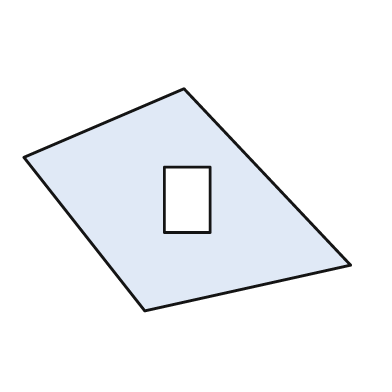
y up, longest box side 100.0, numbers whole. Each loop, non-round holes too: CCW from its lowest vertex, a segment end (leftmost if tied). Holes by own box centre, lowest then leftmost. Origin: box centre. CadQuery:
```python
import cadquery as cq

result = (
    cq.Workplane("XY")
    .moveTo(-13.0, -34.0)
    .lineTo(50.0, -20.0)
    .lineTo(-1.0, 34.0)
    .lineTo(-50.0, 13.0)
    .close()
    .moveTo(-7.0, -10.0)
    .lineTo(7.0, -10.0)
    .lineTo(7.0, 10.0)
    .lineTo(-7.0, 10.0)
    .close()
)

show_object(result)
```